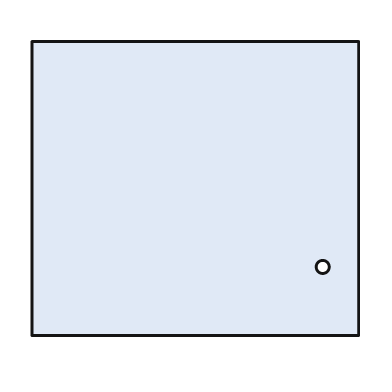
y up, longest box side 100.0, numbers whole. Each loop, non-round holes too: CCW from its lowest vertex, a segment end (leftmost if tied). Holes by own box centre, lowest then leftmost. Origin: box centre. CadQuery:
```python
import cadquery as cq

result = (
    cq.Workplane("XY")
    .moveTo(-50.0, -45.0)
    .lineTo(50.0, -45.0)
    .lineTo(50.0, 45.0)
    .lineTo(-50.0, 45.0)
    .close()
    .moveTo(39.0, -24.0)
    .circle(2.0)
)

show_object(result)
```